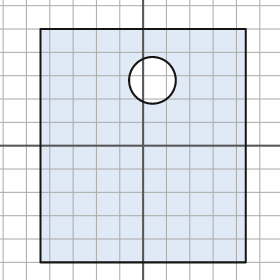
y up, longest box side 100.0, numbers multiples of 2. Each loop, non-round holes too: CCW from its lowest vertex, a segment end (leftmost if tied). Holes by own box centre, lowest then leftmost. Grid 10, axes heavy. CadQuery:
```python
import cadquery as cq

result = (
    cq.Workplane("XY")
    .moveTo(-44.0, -50.0)
    .lineTo(44.0, -50.0)
    .lineTo(44.0, 50.0)
    .lineTo(-44.0, 50.0)
    .close()
    .moveTo(4.0, 28.0)
    .circle(10.0)
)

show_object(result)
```